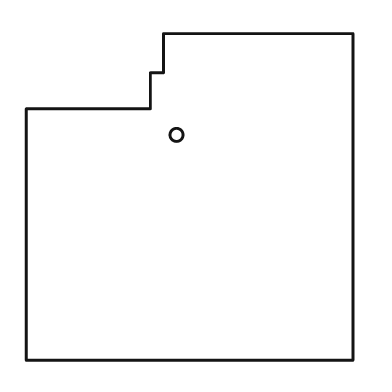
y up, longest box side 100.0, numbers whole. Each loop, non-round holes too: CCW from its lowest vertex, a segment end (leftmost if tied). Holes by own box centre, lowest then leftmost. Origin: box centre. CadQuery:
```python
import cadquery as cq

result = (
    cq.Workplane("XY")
    .moveTo(-50.0, -50.0)
    .lineTo(50.0, -50.0)
    .lineTo(50.0, 50.0)
    .lineTo(-8.0, 50.0)
    .lineTo(-8.0, 38.0)
    .lineTo(-12.0, 38.0)
    .lineTo(-12.0, 27.0)
    .lineTo(-50.0, 27.0)
    .close()
    .moveTo(-4.0, 19.0)
    .circle(2.0)
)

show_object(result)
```